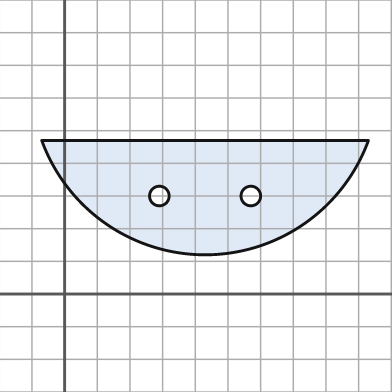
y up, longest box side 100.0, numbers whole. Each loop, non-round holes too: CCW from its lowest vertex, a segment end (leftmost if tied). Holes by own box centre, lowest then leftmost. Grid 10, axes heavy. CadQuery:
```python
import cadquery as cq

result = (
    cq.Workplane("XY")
    .moveTo(-7.0, 47.0)
    .threePointArc((43.0, 12.0), (93.0, 47.0))
    .close()
    .moveTo(29.0, 30.0)
    .circle(3.0)
    .moveTo(57.0, 30.0)
    .circle(3.0)
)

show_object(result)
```